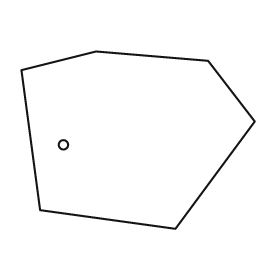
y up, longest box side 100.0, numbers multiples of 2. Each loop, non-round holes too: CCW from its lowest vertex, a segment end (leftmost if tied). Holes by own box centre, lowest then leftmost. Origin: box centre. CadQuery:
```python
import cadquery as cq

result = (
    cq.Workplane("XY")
    .moveTo(16.0, -38.0)
    .lineTo(50.0, 8.0)
    .lineTo(30.0, 34.0)
    .lineTo(-18.0, 38.0)
    .lineTo(-50.0, 30.0)
    .lineTo(-42.0, -30.0)
    .close()
    .moveTo(-32.0, -2.0)
    .circle(2.0)
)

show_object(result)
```